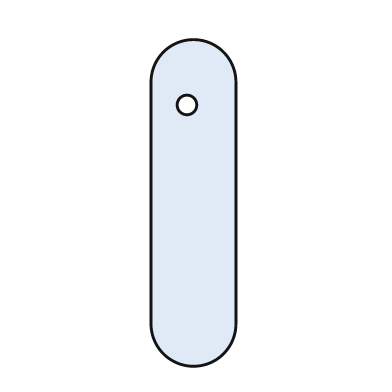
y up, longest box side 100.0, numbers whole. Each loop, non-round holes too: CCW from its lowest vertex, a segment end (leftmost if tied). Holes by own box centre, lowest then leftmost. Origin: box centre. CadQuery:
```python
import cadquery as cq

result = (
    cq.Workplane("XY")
    .moveTo(-13.0, -37.0)
    .threePointArc((0.0, -50.0), (13.0, -37.0))
    .lineTo(13.0, 37.0)
    .threePointArc((0.0, 50.0), (-13.0, 37.0))
    .close()
    .moveTo(-2.0, 30.0)
    .circle(3.0)
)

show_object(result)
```